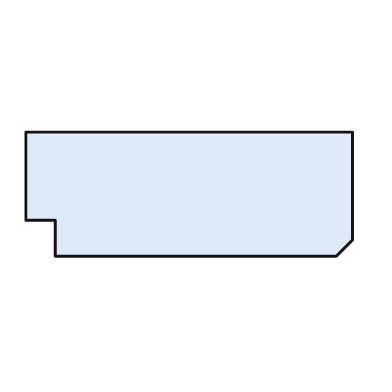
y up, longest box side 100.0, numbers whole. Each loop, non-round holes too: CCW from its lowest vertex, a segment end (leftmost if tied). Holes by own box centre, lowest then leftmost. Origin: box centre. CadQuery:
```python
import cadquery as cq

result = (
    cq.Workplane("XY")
    .moveTo(-41.0, -19.0)
    .lineTo(45.0, -19.0)
    .lineTo(50.0, -14.0)
    .lineTo(50.0, 19.0)
    .lineTo(-50.0, 19.0)
    .lineTo(-50.0, -8.0)
    .lineTo(-41.0, -8.0)
    .close()
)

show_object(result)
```